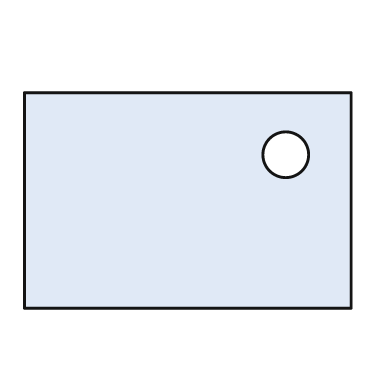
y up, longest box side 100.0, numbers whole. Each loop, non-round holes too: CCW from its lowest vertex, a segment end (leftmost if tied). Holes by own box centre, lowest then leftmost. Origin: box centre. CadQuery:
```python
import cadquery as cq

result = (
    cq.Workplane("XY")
    .moveTo(-50.0, -33.0)
    .lineTo(50.0, -33.0)
    .lineTo(50.0, 33.0)
    .lineTo(-50.0, 33.0)
    .close()
    .moveTo(30.0, 14.0)
    .circle(7.0)
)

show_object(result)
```